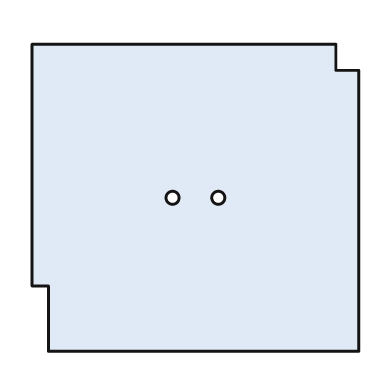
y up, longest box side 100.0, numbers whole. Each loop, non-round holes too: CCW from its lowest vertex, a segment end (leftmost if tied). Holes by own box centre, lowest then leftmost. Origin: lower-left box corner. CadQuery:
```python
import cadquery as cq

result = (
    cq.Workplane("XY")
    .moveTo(5.0, 0.0)
    .lineTo(100.0, 0.0)
    .lineTo(100.0, 86.0)
    .lineTo(93.0, 86.0)
    .lineTo(93.0, 94.0)
    .lineTo(0.0, 94.0)
    .lineTo(0.0, 20.0)
    .lineTo(5.0, 20.0)
    .close()
    .moveTo(43.0, 47.0)
    .circle(2.0)
    .moveTo(57.0, 47.0)
    .circle(2.0)
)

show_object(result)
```